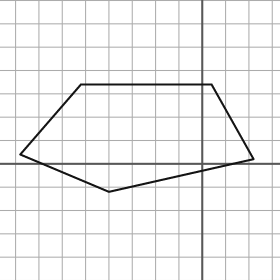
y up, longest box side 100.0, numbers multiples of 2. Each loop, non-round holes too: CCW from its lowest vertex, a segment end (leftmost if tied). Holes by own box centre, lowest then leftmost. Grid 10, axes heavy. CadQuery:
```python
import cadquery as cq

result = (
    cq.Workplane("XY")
    .moveTo(-40.0, -12.0)
    .lineTo(22.0, 2.0)
    .lineTo(4.0, 34.0)
    .lineTo(-52.0, 34.0)
    .lineTo(-78.0, 4.0)
    .close()
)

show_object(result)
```